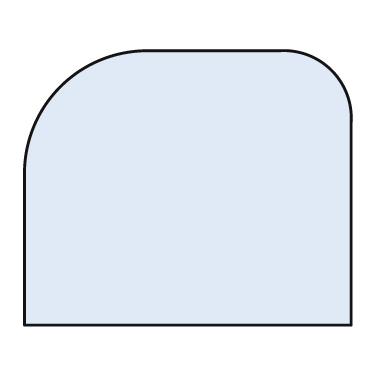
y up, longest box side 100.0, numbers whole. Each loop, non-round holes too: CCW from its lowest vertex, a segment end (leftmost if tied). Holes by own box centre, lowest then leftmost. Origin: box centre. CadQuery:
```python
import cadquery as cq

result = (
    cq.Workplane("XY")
    .moveTo(-50.0, -42.0)
    .lineTo(50.0, -42.0)
    .lineTo(50.0, 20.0)
    .threePointArc((44.0, 36.0), (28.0, 42.0))
    .lineTo(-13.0, 42.0)
    .threePointArc((-39.0, 31.0), (-50.0, 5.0))
    .close()
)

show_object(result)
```